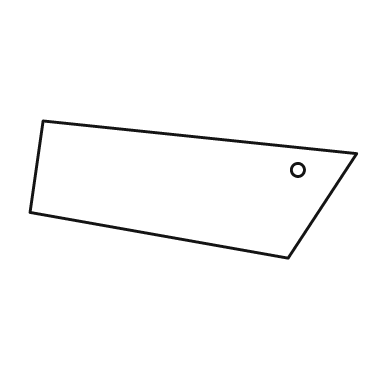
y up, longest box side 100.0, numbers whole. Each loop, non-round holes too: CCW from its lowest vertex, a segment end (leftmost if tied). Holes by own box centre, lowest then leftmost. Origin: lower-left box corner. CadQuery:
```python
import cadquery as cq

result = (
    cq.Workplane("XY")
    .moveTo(79.0, 0.0)
    .lineTo(100.0, 32.0)
    .lineTo(4.0, 42.0)
    .lineTo(0.0, 14.0)
    .close()
    .moveTo(82.0, 27.0)
    .circle(2.0)
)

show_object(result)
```